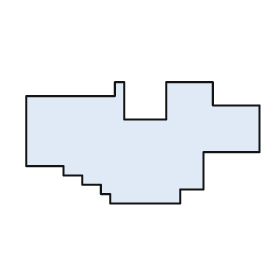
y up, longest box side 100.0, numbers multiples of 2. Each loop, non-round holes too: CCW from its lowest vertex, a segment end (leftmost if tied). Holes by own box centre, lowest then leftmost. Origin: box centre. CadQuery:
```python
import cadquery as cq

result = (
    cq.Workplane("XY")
    .moveTo(-14.0, -26.0)
    .lineTo(16.0, -26.0)
    .lineTo(16.0, -20.0)
    .lineTo(26.0, -20.0)
    .lineTo(26.0, -4.0)
    .lineTo(50.0, -4.0)
    .lineTo(50.0, 16.0)
    .lineTo(30.0, 16.0)
    .lineTo(30.0, 26.0)
    .lineTo(10.0, 26.0)
    .lineTo(10.0, 10.0)
    .lineTo(-8.0, 10.0)
    .lineTo(-8.0, 26.0)
    .lineTo(-12.0, 26.0)
    .lineTo(-12.0, 20.0)
    .lineTo(-50.0, 20.0)
    .lineTo(-50.0, -10.0)
    .lineTo(-34.0, -10.0)
    .lineTo(-34.0, -14.0)
    .lineTo(-26.0, -14.0)
    .lineTo(-26.0, -18.0)
    .lineTo(-18.0, -18.0)
    .lineTo(-18.0, -22.0)
    .lineTo(-14.0, -22.0)
    .close()
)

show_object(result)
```